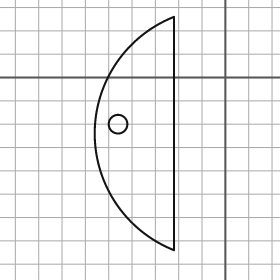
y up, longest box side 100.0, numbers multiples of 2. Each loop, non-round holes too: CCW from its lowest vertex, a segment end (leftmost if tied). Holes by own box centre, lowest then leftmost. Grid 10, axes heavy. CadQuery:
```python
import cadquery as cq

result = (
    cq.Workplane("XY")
    .moveTo(-22.0, -74.0)
    .lineTo(-22.0, 26.0)
    .threePointArc((-56.0, -24.0), (-22.0, -74.0))
    .close()
    .moveTo(-46.0, -20.0)
    .circle(4.0)
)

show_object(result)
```